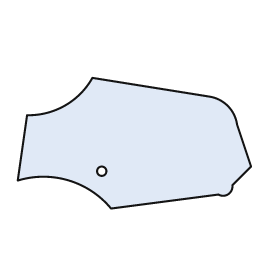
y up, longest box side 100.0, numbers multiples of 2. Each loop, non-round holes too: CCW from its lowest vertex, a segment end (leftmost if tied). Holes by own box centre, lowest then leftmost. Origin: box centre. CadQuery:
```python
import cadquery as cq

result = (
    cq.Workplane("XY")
    .moveTo(-10.0, -28.0)
    .lineTo(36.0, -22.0)
    .threePointArc((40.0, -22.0), (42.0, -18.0))
    .lineTo(50.0, -10.0)
    .lineTo(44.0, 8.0)
    .threePointArc((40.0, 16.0), (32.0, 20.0))
    .lineTo(-18.0, 28.0)
    .threePointArc((-30.0, 16.0), (-46.0, 12.0))
    .lineTo(-50.0, -16.0)
    .threePointArc((-28.0, -16.0), (-10.0, -28.0))
    .close()
    .moveTo(-14.0, -12.0)
    .circle(2.0)
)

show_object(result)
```